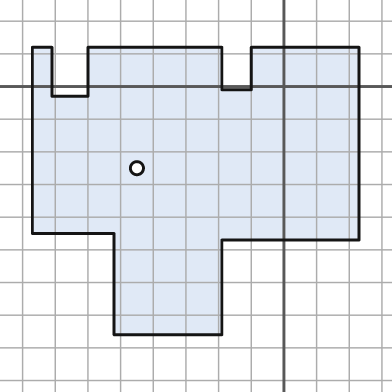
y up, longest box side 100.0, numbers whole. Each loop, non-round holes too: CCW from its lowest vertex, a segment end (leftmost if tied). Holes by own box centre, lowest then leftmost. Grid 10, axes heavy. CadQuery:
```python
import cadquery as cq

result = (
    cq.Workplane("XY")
    .moveTo(-52.0, -76.0)
    .lineTo(-19.0, -76.0)
    .lineTo(-19.0, -47.0)
    .lineTo(23.0, -47.0)
    .lineTo(23.0, 12.0)
    .lineTo(-10.0, 12.0)
    .lineTo(-10.0, -1.0)
    .lineTo(-19.0, -1.0)
    .lineTo(-19.0, 12.0)
    .lineTo(-60.0, 12.0)
    .lineTo(-60.0, -3.0)
    .lineTo(-71.0, -3.0)
    .lineTo(-71.0, 12.0)
    .lineTo(-77.0, 12.0)
    .lineTo(-77.0, -45.0)
    .lineTo(-52.0, -45.0)
    .close()
    .moveTo(-45.0, -25.0)
    .circle(2.0)
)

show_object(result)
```